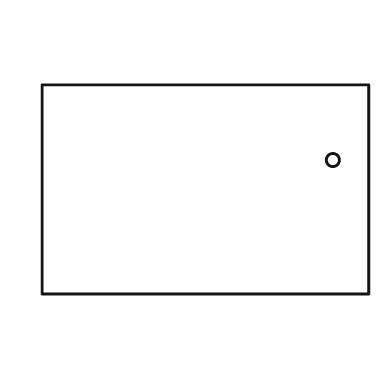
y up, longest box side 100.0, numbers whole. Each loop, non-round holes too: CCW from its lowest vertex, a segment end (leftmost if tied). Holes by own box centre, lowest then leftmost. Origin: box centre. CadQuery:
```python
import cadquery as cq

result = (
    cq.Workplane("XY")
    .moveTo(-50.0, -32.0)
    .lineTo(50.0, -32.0)
    .lineTo(50.0, 32.0)
    .lineTo(-50.0, 32.0)
    .close()
    .moveTo(39.0, 9.0)
    .circle(2.0)
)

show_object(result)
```